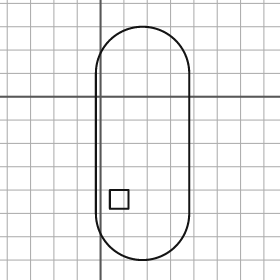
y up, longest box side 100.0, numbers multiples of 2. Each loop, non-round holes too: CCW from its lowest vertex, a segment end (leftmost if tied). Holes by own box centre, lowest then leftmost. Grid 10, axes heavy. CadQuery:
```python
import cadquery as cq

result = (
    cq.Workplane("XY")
    .moveTo(-2.0, -50.0)
    .threePointArc((18.0, -70.0), (38.0, -50.0))
    .lineTo(38.0, 10.0)
    .threePointArc((18.0, 30.0), (-2.0, 10.0))
    .close()
    .moveTo(4.0, -48.0)
    .lineTo(12.0, -48.0)
    .lineTo(12.0, -40.0)
    .lineTo(4.0, -40.0)
    .close()
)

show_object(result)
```